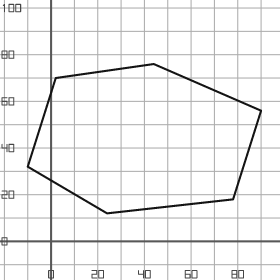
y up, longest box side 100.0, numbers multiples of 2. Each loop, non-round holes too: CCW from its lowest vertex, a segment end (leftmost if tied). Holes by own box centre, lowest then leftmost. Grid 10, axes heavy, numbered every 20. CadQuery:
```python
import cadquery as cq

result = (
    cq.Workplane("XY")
    .moveTo(24.0, 12.0)
    .lineTo(78.0, 18.0)
    .lineTo(90.0, 56.0)
    .lineTo(44.0, 76.0)
    .lineTo(2.0, 70.0)
    .lineTo(-10.0, 32.0)
    .close()
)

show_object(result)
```